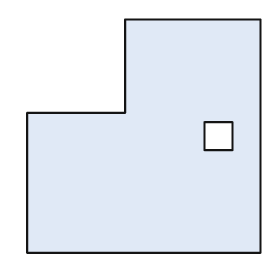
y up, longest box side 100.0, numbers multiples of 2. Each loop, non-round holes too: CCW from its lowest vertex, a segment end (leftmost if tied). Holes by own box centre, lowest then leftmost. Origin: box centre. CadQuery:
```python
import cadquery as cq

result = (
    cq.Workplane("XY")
    .moveTo(-50.0, -50.0)
    .lineTo(50.0, -50.0)
    .lineTo(50.0, 50.0)
    .lineTo(-8.0, 50.0)
    .lineTo(-8.0, 10.0)
    .lineTo(-50.0, 10.0)
    .close()
    .moveTo(26.0, -6.0)
    .lineTo(38.0, -6.0)
    .lineTo(38.0, 6.0)
    .lineTo(26.0, 6.0)
    .close()
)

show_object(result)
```